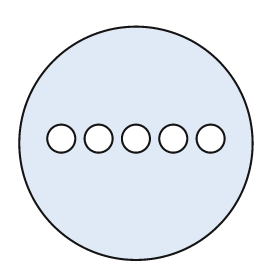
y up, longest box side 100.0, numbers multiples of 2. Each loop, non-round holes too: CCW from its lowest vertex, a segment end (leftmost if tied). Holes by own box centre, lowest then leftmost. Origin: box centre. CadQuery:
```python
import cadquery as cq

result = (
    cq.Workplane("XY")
    .moveTo(0.0, 0.0)
    .circle(50.0)
    .moveTo(-32.0, 2.0)
    .circle(6.0)
    .moveTo(-16.0, 2.0)
    .circle(6.0)
    .moveTo(0.0, 2.0)
    .circle(6.0)
    .moveTo(16.0, 2.0)
    .circle(6.0)
    .moveTo(32.0, 2.0)
    .circle(6.0)
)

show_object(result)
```